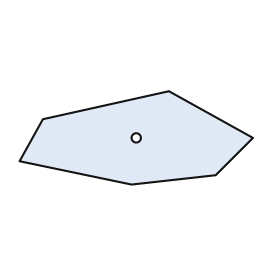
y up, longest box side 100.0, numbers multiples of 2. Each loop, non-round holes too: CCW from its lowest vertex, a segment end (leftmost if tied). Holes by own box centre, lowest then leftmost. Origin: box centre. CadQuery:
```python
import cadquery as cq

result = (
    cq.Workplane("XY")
    .moveTo(-2.0, -20.0)
    .lineTo(34.0, -16.0)
    .lineTo(50.0, 0.0)
    .lineTo(14.0, 20.0)
    .lineTo(-40.0, 8.0)
    .lineTo(-50.0, -10.0)
    .close()
    .moveTo(0.0, 0.0)
    .circle(2.0)
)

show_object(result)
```